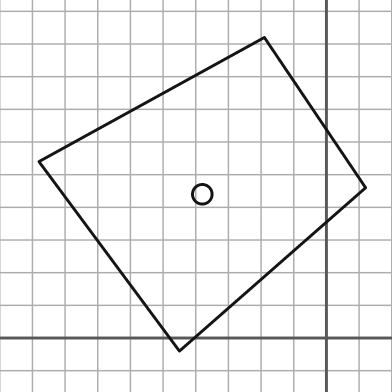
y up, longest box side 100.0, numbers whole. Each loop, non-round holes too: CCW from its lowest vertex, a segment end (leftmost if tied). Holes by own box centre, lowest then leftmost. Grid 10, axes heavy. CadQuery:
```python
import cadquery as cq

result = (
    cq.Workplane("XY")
    .moveTo(-45.0, -4.0)
    .lineTo(12.0, 46.0)
    .lineTo(-19.0, 92.0)
    .lineTo(-88.0, 54.0)
    .close()
    .moveTo(-38.0, 44.0)
    .circle(3.0)
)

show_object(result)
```